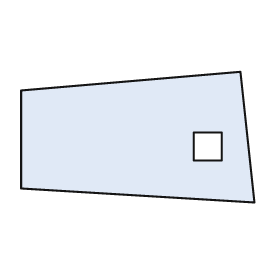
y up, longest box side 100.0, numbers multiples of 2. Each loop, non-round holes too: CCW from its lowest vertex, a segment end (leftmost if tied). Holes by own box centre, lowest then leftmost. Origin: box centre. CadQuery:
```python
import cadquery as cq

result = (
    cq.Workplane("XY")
    .moveTo(50.0, -28.0)
    .lineTo(44.0, 28.0)
    .lineTo(-50.0, 20.0)
    .lineTo(-50.0, -22.0)
    .close()
    .moveTo(24.0, -10.0)
    .lineTo(36.0, -10.0)
    .lineTo(36.0, 2.0)
    .lineTo(24.0, 2.0)
    .close()
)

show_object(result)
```